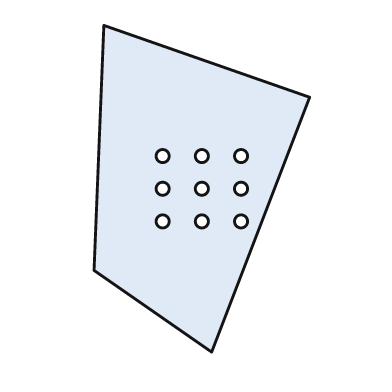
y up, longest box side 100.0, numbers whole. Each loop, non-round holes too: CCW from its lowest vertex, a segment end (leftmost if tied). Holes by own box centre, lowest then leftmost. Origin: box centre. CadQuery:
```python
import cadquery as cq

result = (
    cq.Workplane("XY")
    .moveTo(3.0, -50.0)
    .lineTo(33.0, 28.0)
    .lineTo(-30.0, 50.0)
    .lineTo(-33.0, -25.0)
    .close()
    .moveTo(-12.0, -10.0)
    .circle(2.0)
    .moveTo(0.0, -10.0)
    .circle(2.0)
    .moveTo(12.0, -10.0)
    .circle(2.0)
    .moveTo(-12.0, 0.0)
    .circle(2.0)
    .moveTo(0.0, 0.0)
    .circle(2.0)
    .moveTo(12.0, 0.0)
    .circle(2.0)
    .moveTo(-12.0, 10.0)
    .circle(2.0)
    .moveTo(0.0, 10.0)
    .circle(2.0)
    .moveTo(12.0, 10.0)
    .circle(2.0)
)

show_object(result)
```